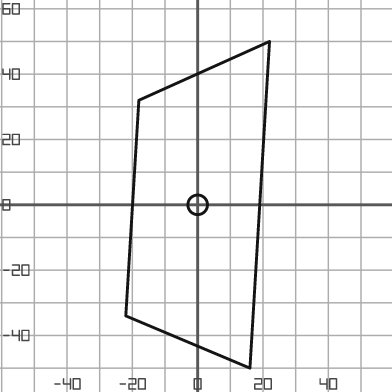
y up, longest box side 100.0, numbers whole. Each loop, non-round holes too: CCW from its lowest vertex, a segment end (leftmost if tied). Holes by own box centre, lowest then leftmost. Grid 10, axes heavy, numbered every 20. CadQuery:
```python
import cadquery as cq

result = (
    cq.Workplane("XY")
    .moveTo(16.0, -50.0)
    .lineTo(22.0, 50.0)
    .lineTo(-18.0, 32.0)
    .lineTo(-22.0, -34.0)
    .close()
    .moveTo(0.0, 0.0)
    .circle(3.0)
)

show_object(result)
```